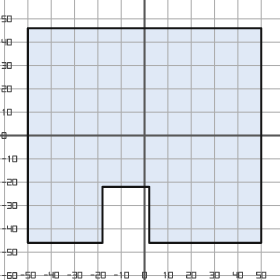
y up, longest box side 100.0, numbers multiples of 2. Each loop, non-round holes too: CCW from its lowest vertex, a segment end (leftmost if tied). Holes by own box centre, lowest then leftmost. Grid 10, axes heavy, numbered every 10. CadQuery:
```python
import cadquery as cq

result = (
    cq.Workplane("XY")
    .moveTo(-50.0, -46.0)
    .lineTo(-18.0, -46.0)
    .lineTo(-18.0, -22.0)
    .lineTo(2.0, -22.0)
    .lineTo(2.0, -46.0)
    .lineTo(50.0, -46.0)
    .lineTo(50.0, 46.0)
    .lineTo(-50.0, 46.0)
    .close()
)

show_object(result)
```